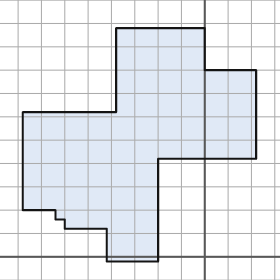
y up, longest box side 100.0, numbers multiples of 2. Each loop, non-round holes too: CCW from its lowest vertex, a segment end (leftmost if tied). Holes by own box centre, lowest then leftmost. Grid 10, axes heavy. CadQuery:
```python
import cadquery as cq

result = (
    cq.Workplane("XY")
    .moveTo(-42.0, -2.0)
    .lineTo(-20.0, -2.0)
    .lineTo(-20.0, 42.0)
    .lineTo(22.0, 42.0)
    .lineTo(22.0, 80.0)
    .lineTo(0.0, 80.0)
    .lineTo(0.0, 98.0)
    .lineTo(-38.0, 98.0)
    .lineTo(-38.0, 62.0)
    .lineTo(-78.0, 62.0)
    .lineTo(-78.0, 20.0)
    .lineTo(-64.0, 20.0)
    .lineTo(-64.0, 16.0)
    .lineTo(-60.0, 16.0)
    .lineTo(-60.0, 12.0)
    .lineTo(-42.0, 12.0)
    .close()
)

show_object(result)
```